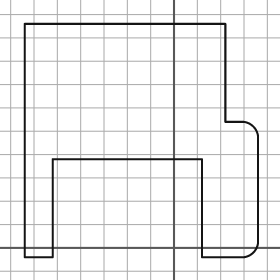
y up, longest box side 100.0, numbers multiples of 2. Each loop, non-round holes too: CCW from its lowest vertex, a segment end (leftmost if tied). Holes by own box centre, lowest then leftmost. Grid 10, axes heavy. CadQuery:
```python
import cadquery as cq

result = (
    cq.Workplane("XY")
    .moveTo(-64.0, -4.0)
    .lineTo(-52.0, -4.0)
    .lineTo(-52.0, 38.0)
    .lineTo(12.0, 38.0)
    .lineTo(12.0, -4.0)
    .lineTo(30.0, -4.0)
    .threePointArc((34.0, -2.0), (36.0, 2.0))
    .lineTo(36.0, 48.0)
    .threePointArc((34.0, 52.0), (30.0, 54.0))
    .lineTo(22.0, 54.0)
    .lineTo(22.0, 96.0)
    .lineTo(-64.0, 96.0)
    .close()
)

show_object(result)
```